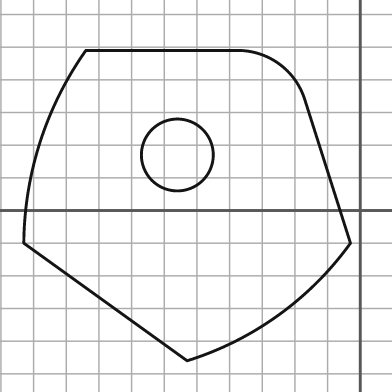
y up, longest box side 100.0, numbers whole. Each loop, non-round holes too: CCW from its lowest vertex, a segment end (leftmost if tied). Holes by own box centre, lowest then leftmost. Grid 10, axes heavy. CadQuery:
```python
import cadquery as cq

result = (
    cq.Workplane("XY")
    .moveTo(-53.0, -46.0)
    .threePointArc((-25.0, -32.0), (-3.0, -10.0))
    .lineTo(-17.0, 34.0)
    .threePointArc((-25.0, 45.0), (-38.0, 49.0))
    .lineTo(-84.0, 49.0)
    .threePointArc((-98.0, 21.0), (-103.0, -10.0))
    .close()
    .moveTo(-56.0, 17.0)
    .circle(11.0)
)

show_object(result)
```